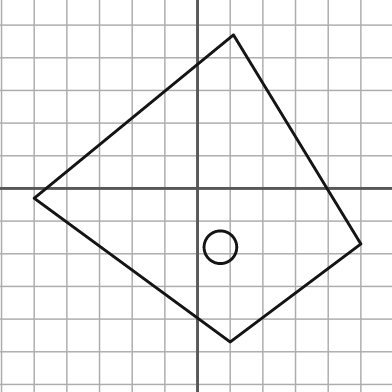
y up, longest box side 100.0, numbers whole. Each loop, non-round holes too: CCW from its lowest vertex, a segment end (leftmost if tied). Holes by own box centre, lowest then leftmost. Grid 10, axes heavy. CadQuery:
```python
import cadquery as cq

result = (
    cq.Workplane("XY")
    .moveTo(10.0, -47.0)
    .lineTo(50.0, -17.0)
    .lineTo(11.0, 47.0)
    .lineTo(-50.0, -3.0)
    .close()
    .moveTo(7.0, -18.0)
    .circle(5.0)
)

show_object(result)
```